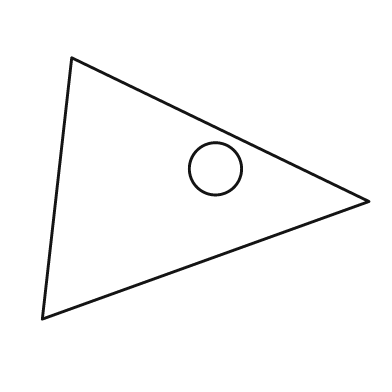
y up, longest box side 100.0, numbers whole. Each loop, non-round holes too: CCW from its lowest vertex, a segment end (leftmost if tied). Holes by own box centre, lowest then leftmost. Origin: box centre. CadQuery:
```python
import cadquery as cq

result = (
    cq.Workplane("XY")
    .moveTo(-50.0, -40.0)
    .lineTo(50.0, -4.0)
    .lineTo(-41.0, 40.0)
    .close()
    .moveTo(3.0, 6.0)
    .circle(8.0)
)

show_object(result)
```